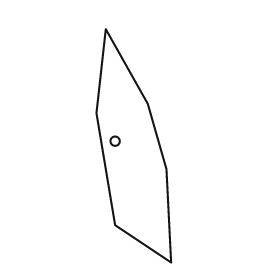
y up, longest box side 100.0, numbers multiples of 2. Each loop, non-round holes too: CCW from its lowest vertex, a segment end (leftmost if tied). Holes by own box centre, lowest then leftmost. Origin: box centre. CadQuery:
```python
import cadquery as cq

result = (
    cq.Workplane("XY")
    .moveTo(16.0, -50.0)
    .lineTo(14.0, -10.0)
    .lineTo(6.0, 18.0)
    .lineTo(-12.0, 50.0)
    .lineTo(-16.0, 14.0)
    .lineTo(-8.0, -34.0)
    .close()
    .moveTo(-8.0, 2.0)
    .circle(2.0)
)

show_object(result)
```